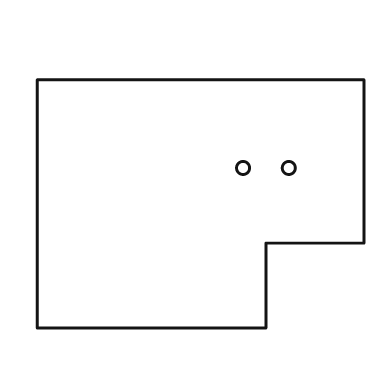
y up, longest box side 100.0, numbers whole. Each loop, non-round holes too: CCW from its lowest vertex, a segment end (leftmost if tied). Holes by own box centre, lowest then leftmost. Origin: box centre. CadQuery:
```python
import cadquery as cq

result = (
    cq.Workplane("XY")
    .moveTo(-50.0, -38.0)
    .lineTo(20.0, -38.0)
    .lineTo(20.0, -12.0)
    .lineTo(50.0, -12.0)
    .lineTo(50.0, 38.0)
    .lineTo(-50.0, 38.0)
    .close()
    .moveTo(13.0, 11.0)
    .circle(2.0)
    .moveTo(27.0, 11.0)
    .circle(2.0)
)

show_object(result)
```